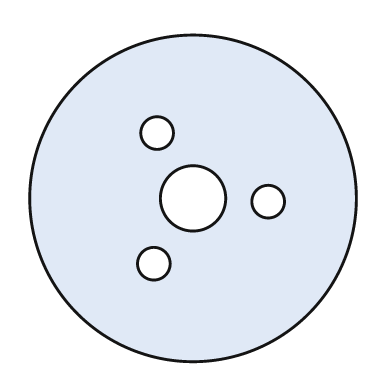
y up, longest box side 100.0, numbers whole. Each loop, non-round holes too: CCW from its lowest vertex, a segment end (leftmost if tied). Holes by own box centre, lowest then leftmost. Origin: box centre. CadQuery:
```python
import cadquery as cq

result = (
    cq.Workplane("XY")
    .moveTo(0.0, 0.0)
    .circle(50.0)
    .moveTo(-12.0, -20.0)
    .circle(5.0)
    .moveTo(23.0, -1.0)
    .circle(5.0)
    .moveTo(0.0, 0.0)
    .circle(10.0)
    .moveTo(-11.0, 20.0)
    .circle(5.0)
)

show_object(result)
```